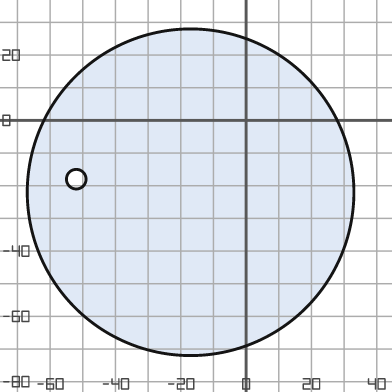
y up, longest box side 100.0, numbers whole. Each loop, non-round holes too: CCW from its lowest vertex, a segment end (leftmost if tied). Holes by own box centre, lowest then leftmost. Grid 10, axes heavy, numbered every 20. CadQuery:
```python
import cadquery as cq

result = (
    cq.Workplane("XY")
    .moveTo(-17.0, -22.0)
    .circle(50.0)
    .moveTo(-52.0, -18.0)
    .circle(3.0)
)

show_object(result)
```